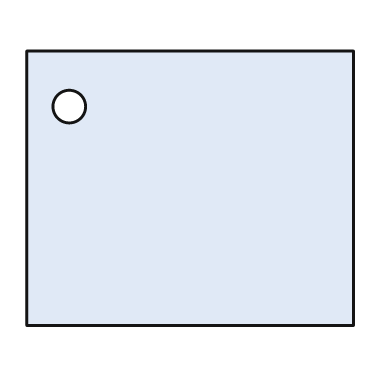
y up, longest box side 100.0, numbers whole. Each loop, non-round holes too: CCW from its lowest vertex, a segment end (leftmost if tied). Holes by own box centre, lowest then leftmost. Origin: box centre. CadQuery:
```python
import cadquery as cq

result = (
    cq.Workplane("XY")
    .moveTo(-50.0, -42.0)
    .lineTo(50.0, -42.0)
    .lineTo(50.0, 42.0)
    .lineTo(-50.0, 42.0)
    .close()
    .moveTo(-37.0, 25.0)
    .circle(5.0)
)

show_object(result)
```